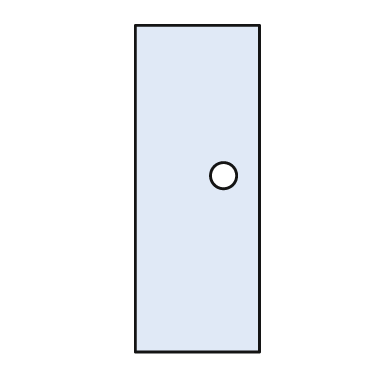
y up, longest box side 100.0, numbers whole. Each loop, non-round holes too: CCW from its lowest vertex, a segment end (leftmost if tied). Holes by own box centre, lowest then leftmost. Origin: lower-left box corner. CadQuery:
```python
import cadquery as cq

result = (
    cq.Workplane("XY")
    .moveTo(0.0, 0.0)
    .lineTo(38.0, 0.0)
    .lineTo(38.0, 100.0)
    .lineTo(0.0, 100.0)
    .close()
    .moveTo(27.0, 54.0)
    .circle(4.0)
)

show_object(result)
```